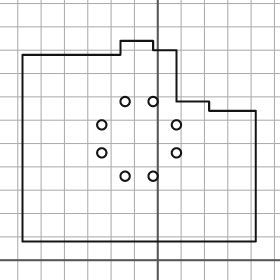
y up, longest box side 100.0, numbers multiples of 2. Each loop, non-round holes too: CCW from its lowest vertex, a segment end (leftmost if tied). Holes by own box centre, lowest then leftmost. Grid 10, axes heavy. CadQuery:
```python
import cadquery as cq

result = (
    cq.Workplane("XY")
    .moveTo(-58.0, 8.0)
    .lineTo(42.0, 8.0)
    .lineTo(42.0, 64.0)
    .lineTo(22.0, 64.0)
    .lineTo(22.0, 68.0)
    .lineTo(8.0, 68.0)
    .lineTo(8.0, 90.0)
    .lineTo(-2.0, 90.0)
    .lineTo(-2.0, 94.0)
    .lineTo(-16.0, 94.0)
    .lineTo(-16.0, 88.0)
    .lineTo(-58.0, 88.0)
    .close()
    .moveTo(-14.0, 36.0)
    .circle(2.0)
    .moveTo(-2.0, 36.0)
    .circle(2.0)
    .moveTo(-24.0, 46.0)
    .circle(2.0)
    .moveTo(8.0, 46.0)
    .circle(2.0)
    .moveTo(-24.0, 58.0)
    .circle(2.0)
    .moveTo(8.0, 58.0)
    .circle(2.0)
    .moveTo(-14.0, 68.0)
    .circle(2.0)
    .moveTo(-2.0, 68.0)
    .circle(2.0)
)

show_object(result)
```